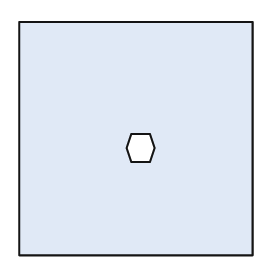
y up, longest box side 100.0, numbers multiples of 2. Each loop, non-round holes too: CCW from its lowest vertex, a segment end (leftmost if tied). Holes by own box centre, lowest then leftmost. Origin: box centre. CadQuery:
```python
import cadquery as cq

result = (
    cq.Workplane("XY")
    .moveTo(-50.0, -50.0)
    .lineTo(50.0, -50.0)
    .lineTo(50.0, 50.0)
    .lineTo(-50.0, 50.0)
    .close()
    .moveTo(-2.0, -10.0)
    .lineTo(6.0, -10.0)
    .lineTo(8.0, -4.0)
    .lineTo(6.0, 2.0)
    .lineTo(-2.0, 2.0)
    .lineTo(-4.0, -4.0)
    .close()
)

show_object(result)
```